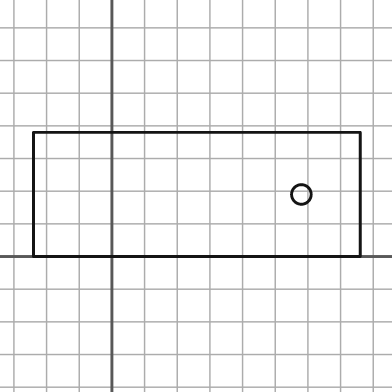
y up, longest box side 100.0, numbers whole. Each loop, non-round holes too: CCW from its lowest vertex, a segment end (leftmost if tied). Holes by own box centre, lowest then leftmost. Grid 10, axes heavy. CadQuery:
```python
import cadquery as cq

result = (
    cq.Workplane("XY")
    .moveTo(-24.0, 0.0)
    .lineTo(76.0, 0.0)
    .lineTo(76.0, 38.0)
    .lineTo(-24.0, 38.0)
    .close()
    .moveTo(58.0, 19.0)
    .circle(3.0)
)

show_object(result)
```